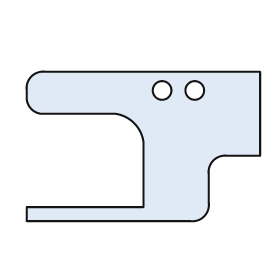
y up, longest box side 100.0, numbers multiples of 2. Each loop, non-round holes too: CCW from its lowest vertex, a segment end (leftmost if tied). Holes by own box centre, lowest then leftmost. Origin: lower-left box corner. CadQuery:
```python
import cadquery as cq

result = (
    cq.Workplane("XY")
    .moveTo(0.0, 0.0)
    .lineTo(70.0, 0.0)
    .threePointArc((76.0, 2.0), (78.0, 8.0))
    .lineTo(78.0, 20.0)
    .threePointArc((80.0, 26.0), (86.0, 28.0))
    .lineTo(100.0, 28.0)
    .lineTo(100.0, 64.0)
    .lineTo(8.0, 64.0)
    .threePointArc((2.0, 62.0), (0.0, 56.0))
    .lineTo(0.0, 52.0)
    .threePointArc((2.0, 48.0), (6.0, 46.0))
    .lineTo(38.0, 46.0)
    .threePointArc((46.0, 42.0), (50.0, 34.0))
    .lineTo(50.0, 6.0)
    .lineTo(0.0, 6.0)
    .close()
    .moveTo(58.0, 56.0)
    .circle(4.0)
    .moveTo(72.0, 56.0)
    .circle(4.0)
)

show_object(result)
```